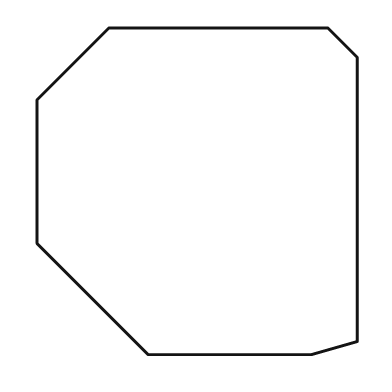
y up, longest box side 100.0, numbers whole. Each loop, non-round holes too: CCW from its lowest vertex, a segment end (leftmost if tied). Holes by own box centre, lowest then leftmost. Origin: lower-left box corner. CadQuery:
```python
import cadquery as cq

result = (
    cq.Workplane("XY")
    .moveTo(34.0, 0.0)
    .lineTo(84.0, 0.0)
    .lineTo(98.0, 4.0)
    .lineTo(98.0, 91.0)
    .lineTo(89.0, 100.0)
    .lineTo(22.0, 100.0)
    .lineTo(0.0, 78.0)
    .lineTo(0.0, 34.0)
    .close()
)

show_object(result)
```